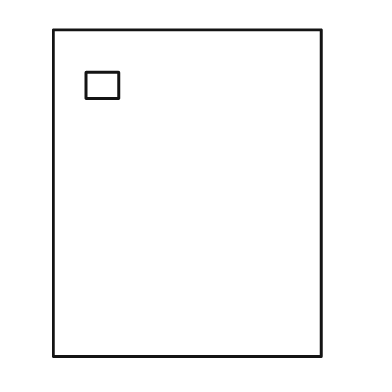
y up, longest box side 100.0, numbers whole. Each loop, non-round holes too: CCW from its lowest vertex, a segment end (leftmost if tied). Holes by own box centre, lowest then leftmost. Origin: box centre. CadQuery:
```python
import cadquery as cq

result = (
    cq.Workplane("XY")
    .moveTo(-41.0, -50.0)
    .lineTo(41.0, -50.0)
    .lineTo(41.0, 50.0)
    .lineTo(-41.0, 50.0)
    .close()
    .moveTo(-31.0, 29.0)
    .lineTo(-21.0, 29.0)
    .lineTo(-21.0, 37.0)
    .lineTo(-31.0, 37.0)
    .close()
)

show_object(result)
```